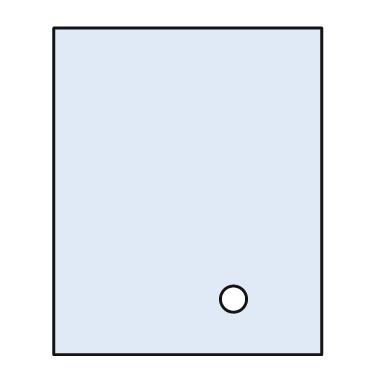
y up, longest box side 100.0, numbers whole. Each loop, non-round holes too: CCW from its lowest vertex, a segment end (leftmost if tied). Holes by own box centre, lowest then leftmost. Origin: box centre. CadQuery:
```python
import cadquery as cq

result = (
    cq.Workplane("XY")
    .moveTo(-41.0, -50.0)
    .lineTo(41.0, -50.0)
    .lineTo(41.0, 50.0)
    .lineTo(-41.0, 50.0)
    .close()
    .moveTo(14.0, -33.0)
    .circle(4.0)
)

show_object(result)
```